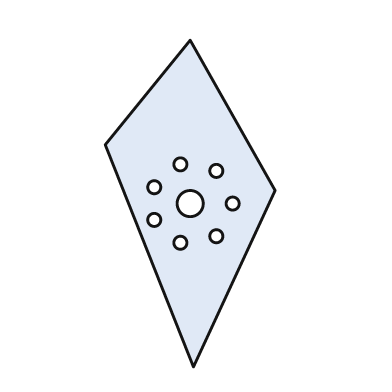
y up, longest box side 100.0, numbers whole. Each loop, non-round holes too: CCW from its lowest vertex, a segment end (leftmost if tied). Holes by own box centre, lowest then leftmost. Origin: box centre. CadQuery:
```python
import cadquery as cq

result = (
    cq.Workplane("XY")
    .moveTo(1.0, -50.0)
    .lineTo(26.0, 4.0)
    .lineTo(0.0, 50.0)
    .lineTo(-26.0, 18.0)
    .close()
    .moveTo(-3.0, -12.0)
    .circle(2.0)
    .moveTo(8.0, -10.0)
    .circle(2.0)
    .moveTo(-11.0, -5.0)
    .circle(2.0)
    .moveTo(0.0, 0.0)
    .circle(4.0)
    .moveTo(13.0, 0.0)
    .circle(2.0)
    .moveTo(-11.0, 5.0)
    .circle(2.0)
    .moveTo(8.0, 10.0)
    .circle(2.0)
    .moveTo(-3.0, 12.0)
    .circle(2.0)
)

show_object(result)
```